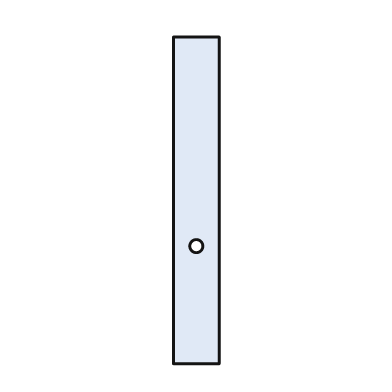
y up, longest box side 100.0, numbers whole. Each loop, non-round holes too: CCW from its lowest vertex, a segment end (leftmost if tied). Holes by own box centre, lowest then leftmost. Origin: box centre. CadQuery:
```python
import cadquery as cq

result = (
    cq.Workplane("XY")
    .moveTo(-7.0, -50.0)
    .lineTo(7.0, -50.0)
    .lineTo(7.0, 50.0)
    .lineTo(-7.0, 50.0)
    .close()
    .moveTo(0.0, -14.0)
    .circle(2.0)
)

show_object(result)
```